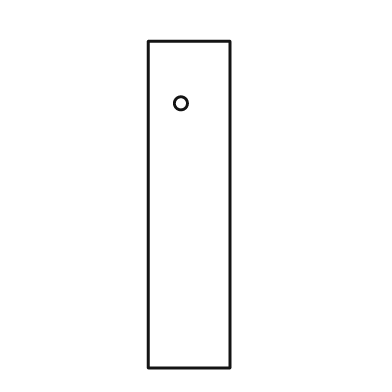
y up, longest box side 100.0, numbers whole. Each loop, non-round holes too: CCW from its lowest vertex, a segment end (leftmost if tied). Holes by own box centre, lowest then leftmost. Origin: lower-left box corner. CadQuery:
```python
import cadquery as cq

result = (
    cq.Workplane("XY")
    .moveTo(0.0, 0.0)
    .lineTo(25.0, 0.0)
    .lineTo(25.0, 100.0)
    .lineTo(0.0, 100.0)
    .close()
    .moveTo(10.0, 81.0)
    .circle(2.0)
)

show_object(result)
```